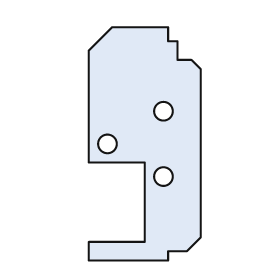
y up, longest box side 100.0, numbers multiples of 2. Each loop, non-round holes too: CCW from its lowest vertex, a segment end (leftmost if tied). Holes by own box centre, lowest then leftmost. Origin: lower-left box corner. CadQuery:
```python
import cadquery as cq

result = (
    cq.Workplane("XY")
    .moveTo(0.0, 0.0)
    .lineTo(34.0, 0.0)
    .lineTo(34.0, 4.0)
    .lineTo(42.0, 4.0)
    .lineTo(48.0, 10.0)
    .lineTo(48.0, 82.0)
    .lineTo(44.0, 86.0)
    .lineTo(38.0, 86.0)
    .lineTo(38.0, 94.0)
    .lineTo(34.0, 94.0)
    .lineTo(34.0, 100.0)
    .lineTo(10.0, 100.0)
    .lineTo(0.0, 90.0)
    .lineTo(0.0, 42.0)
    .lineTo(24.0, 42.0)
    .lineTo(24.0, 8.0)
    .lineTo(0.0, 8.0)
    .close()
    .moveTo(32.0, 36.0)
    .circle(4.0)
    .moveTo(8.0, 50.0)
    .circle(4.0)
    .moveTo(32.0, 64.0)
    .circle(4.0)
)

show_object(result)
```